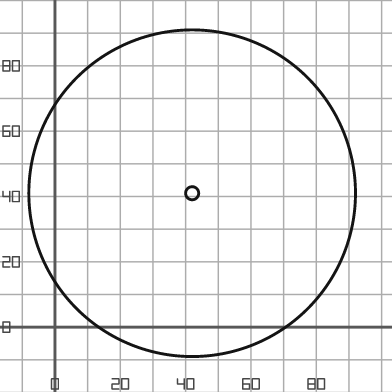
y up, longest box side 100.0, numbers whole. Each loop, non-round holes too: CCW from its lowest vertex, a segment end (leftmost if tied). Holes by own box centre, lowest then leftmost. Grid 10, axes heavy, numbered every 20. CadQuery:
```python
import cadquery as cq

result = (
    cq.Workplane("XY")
    .moveTo(42.0, 41.0)
    .circle(50.0)
    .moveTo(42.0, 41.0)
    .circle(2.0)
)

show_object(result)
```